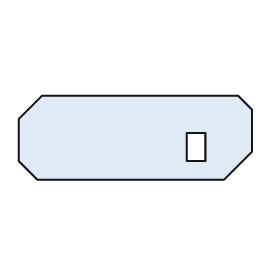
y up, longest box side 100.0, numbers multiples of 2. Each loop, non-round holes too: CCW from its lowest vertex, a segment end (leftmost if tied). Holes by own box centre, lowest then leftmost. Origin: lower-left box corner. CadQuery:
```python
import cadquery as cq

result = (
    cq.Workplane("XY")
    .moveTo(8.0, 0.0)
    .lineTo(88.0, 0.0)
    .lineTo(100.0, 12.0)
    .lineTo(100.0, 30.0)
    .lineTo(94.0, 36.0)
    .lineTo(10.0, 36.0)
    .lineTo(0.0, 26.0)
    .lineTo(0.0, 8.0)
    .close()
    .moveTo(72.0, 8.0)
    .lineTo(80.0, 8.0)
    .lineTo(80.0, 20.0)
    .lineTo(72.0, 20.0)
    .close()
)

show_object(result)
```